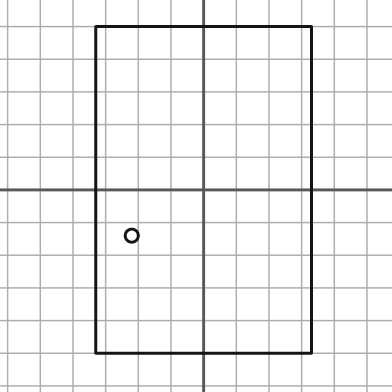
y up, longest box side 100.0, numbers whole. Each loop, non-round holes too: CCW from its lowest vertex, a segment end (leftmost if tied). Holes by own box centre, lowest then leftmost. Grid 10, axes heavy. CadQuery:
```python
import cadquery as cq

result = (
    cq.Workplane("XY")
    .moveTo(-33.0, -50.0)
    .lineTo(33.0, -50.0)
    .lineTo(33.0, 50.0)
    .lineTo(-33.0, 50.0)
    .close()
    .moveTo(-22.0, -14.0)
    .circle(2.0)
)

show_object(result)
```